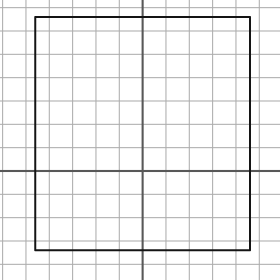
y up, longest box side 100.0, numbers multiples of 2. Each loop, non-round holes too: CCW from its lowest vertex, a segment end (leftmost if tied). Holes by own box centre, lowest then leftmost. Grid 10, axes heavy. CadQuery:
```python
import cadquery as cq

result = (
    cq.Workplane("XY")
    .moveTo(-46.0, -34.0)
    .lineTo(46.0, -34.0)
    .lineTo(46.0, 66.0)
    .lineTo(-46.0, 66.0)
    .close()
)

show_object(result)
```